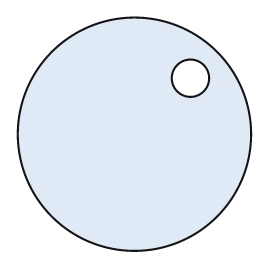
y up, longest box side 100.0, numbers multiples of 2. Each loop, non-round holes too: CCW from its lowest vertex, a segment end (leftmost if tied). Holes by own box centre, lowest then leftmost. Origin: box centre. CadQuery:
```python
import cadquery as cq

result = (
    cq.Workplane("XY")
    .moveTo(0.0, 0.0)
    .circle(50.0)
    .moveTo(24.0, 24.0)
    .circle(8.0)
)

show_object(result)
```